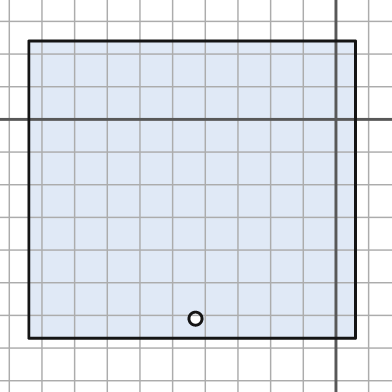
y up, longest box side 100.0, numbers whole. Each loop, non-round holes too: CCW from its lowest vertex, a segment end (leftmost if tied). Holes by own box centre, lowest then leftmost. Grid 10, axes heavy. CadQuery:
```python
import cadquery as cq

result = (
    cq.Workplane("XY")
    .moveTo(-94.0, -67.0)
    .lineTo(6.0, -67.0)
    .lineTo(6.0, 24.0)
    .lineTo(-94.0, 24.0)
    .close()
    .moveTo(-43.0, -61.0)
    .circle(2.0)
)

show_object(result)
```